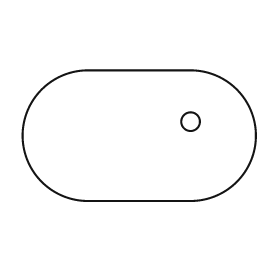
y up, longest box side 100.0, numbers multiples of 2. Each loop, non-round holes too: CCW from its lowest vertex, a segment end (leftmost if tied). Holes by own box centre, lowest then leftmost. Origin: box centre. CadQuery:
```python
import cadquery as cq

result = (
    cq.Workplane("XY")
    .moveTo(-22.0, -28.0)
    .lineTo(22.0, -28.0)
    .threePointArc((50.0, 0.0), (22.0, 28.0))
    .lineTo(-22.0, 28.0)
    .threePointArc((-50.0, 0.0), (-22.0, -28.0))
    .close()
    .moveTo(22.0, 6.0)
    .circle(4.0)
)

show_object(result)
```